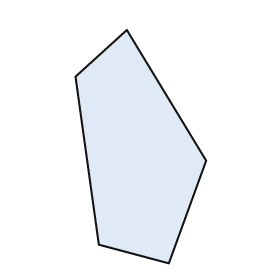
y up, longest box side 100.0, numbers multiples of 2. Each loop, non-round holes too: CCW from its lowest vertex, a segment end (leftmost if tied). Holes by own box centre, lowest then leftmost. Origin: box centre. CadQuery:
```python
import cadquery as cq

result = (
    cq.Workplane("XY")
    .moveTo(12.0, -50.0)
    .lineTo(28.0, -6.0)
    .lineTo(-6.0, 50.0)
    .lineTo(-28.0, 30.0)
    .lineTo(-18.0, -42.0)
    .close()
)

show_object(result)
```